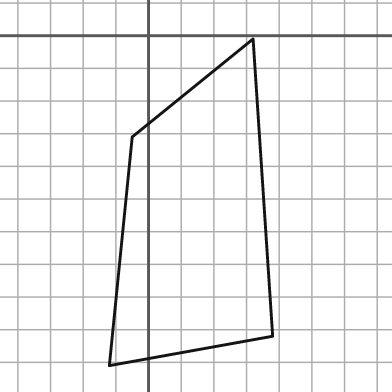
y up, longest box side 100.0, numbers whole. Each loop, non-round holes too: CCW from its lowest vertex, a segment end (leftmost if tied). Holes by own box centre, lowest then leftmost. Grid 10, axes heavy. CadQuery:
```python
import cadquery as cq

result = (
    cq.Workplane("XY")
    .moveTo(-12.0, -101.0)
    .lineTo(38.0, -92.0)
    .lineTo(32.0, -1.0)
    .lineTo(-5.0, -31.0)
    .close()
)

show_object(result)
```